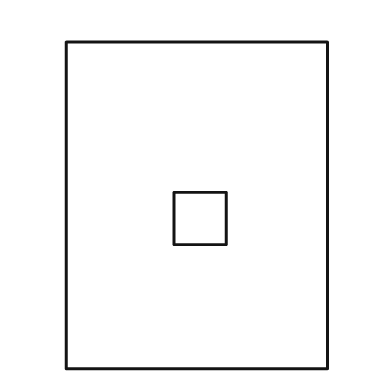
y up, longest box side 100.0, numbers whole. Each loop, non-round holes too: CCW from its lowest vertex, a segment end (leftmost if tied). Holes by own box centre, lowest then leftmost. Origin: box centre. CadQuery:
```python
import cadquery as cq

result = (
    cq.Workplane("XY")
    .moveTo(-40.0, -50.0)
    .lineTo(40.0, -50.0)
    .lineTo(40.0, 50.0)
    .lineTo(-40.0, 50.0)
    .close()
    .moveTo(-7.0, -12.0)
    .lineTo(9.0, -12.0)
    .lineTo(9.0, 4.0)
    .lineTo(-7.0, 4.0)
    .close()
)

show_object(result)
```